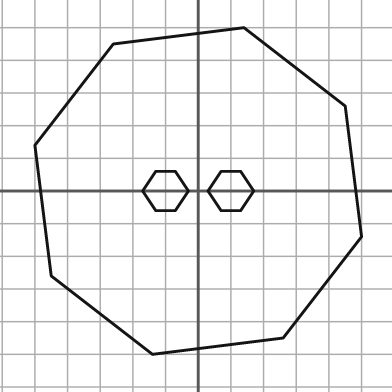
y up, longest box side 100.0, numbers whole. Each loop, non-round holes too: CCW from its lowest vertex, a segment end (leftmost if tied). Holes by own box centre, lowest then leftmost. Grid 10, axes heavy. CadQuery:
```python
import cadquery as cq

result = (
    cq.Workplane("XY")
    .moveTo(-14.0, -50.0)
    .lineTo(26.0, -45.0)
    .lineTo(50.0, -14.0)
    .lineTo(45.0, 26.0)
    .lineTo(14.0, 50.0)
    .lineTo(-26.0, 45.0)
    .lineTo(-50.0, 14.0)
    .lineTo(-45.0, -26.0)
    .close()
    .moveTo(-13.0, -6.0)
    .lineTo(-7.0, -6.0)
    .lineTo(-3.0, 0.0)
    .lineTo(-7.0, 6.0)
    .lineTo(-13.0, 6.0)
    .lineTo(-17.0, 0.0)
    .close()
    .moveTo(7.0, -6.0)
    .lineTo(13.0, -6.0)
    .lineTo(17.0, 0.0)
    .lineTo(13.0, 6.0)
    .lineTo(7.0, 6.0)
    .lineTo(3.0, 0.0)
    .close()
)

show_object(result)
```